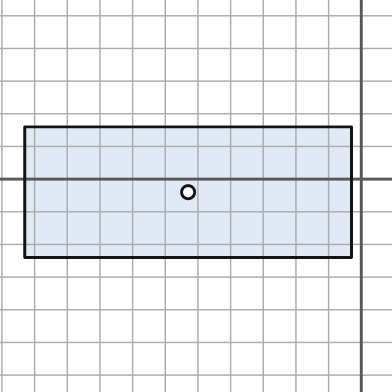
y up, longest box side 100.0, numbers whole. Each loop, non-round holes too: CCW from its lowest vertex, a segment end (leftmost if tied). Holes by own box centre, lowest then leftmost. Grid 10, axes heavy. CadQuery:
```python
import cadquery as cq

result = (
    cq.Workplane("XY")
    .moveTo(-103.0, -24.0)
    .lineTo(-3.0, -24.0)
    .lineTo(-3.0, 16.0)
    .lineTo(-103.0, 16.0)
    .close()
    .moveTo(-53.0, -4.0)
    .circle(2.0)
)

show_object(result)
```